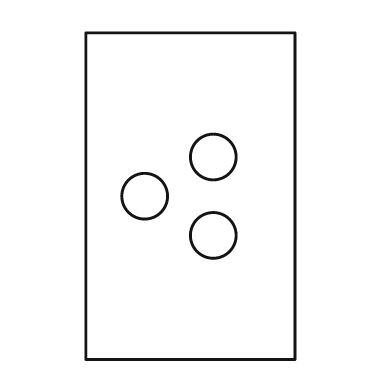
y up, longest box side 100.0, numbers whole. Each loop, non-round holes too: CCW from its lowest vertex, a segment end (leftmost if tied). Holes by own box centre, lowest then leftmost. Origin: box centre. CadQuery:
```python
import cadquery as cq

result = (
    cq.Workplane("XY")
    .moveTo(-32.0, -50.0)
    .lineTo(32.0, -50.0)
    .lineTo(32.0, 50.0)
    .lineTo(-32.0, 50.0)
    .close()
    .moveTo(7.0, -12.0)
    .circle(7.0)
    .moveTo(-14.0, 0.0)
    .circle(7.0)
    .moveTo(7.0, 12.0)
    .circle(7.0)
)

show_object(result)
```